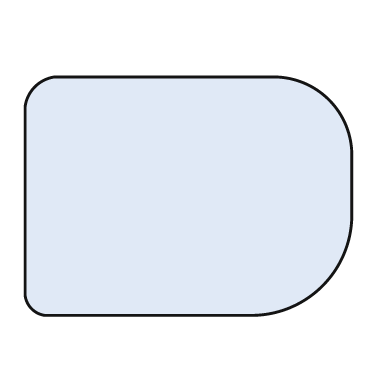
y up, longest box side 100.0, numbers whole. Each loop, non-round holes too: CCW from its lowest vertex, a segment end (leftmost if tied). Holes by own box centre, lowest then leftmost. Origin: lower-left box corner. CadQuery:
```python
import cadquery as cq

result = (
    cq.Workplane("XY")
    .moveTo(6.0, 0.0)
    .lineTo(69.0, 0.0)
    .threePointArc((91.0, 9.0), (100.0, 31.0))
    .lineTo(100.0, 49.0)
    .threePointArc((93.0, 66.0), (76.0, 73.0))
    .lineTo(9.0, 73.0)
    .threePointArc((3.0, 70.0), (0.0, 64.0))
    .lineTo(0.0, 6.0)
    .threePointArc((2.0, 2.0), (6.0, 0.0))
    .close()
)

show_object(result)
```